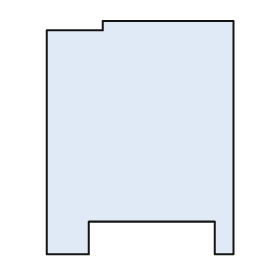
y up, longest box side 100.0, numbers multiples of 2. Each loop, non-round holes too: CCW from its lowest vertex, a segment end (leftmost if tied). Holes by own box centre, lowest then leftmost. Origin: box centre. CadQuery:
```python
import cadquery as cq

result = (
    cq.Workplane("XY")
    .moveTo(-40.0, -50.0)
    .lineTo(-22.0, -50.0)
    .lineTo(-22.0, -36.0)
    .lineTo(32.0, -36.0)
    .lineTo(32.0, -50.0)
    .lineTo(40.0, -50.0)
    .lineTo(40.0, 50.0)
    .lineTo(-16.0, 50.0)
    .lineTo(-16.0, 46.0)
    .lineTo(-40.0, 46.0)
    .close()
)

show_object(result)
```